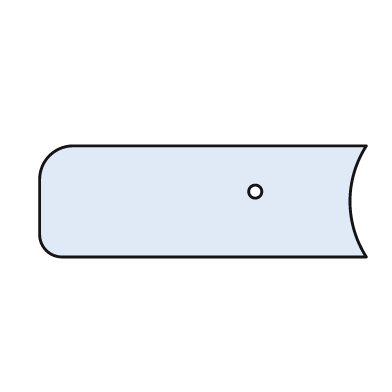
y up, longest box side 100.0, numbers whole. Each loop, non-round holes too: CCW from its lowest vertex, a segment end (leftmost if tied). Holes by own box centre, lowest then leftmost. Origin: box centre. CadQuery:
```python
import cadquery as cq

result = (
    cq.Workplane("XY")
    .moveTo(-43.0, -17.0)
    .lineTo(50.0, -17.0)
    .threePointArc((45.0, 0.0), (50.0, 17.0))
    .lineTo(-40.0, 17.0)
    .threePointArc((-47.0, 14.0), (-50.0, 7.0))
    .lineTo(-50.0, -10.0)
    .threePointArc((-48.0, -15.0), (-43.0, -17.0))
    .close()
    .moveTo(16.0, 3.0)
    .circle(2.0)
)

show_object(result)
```